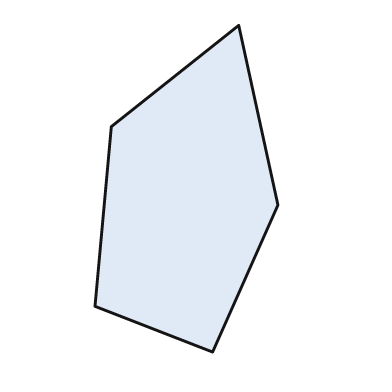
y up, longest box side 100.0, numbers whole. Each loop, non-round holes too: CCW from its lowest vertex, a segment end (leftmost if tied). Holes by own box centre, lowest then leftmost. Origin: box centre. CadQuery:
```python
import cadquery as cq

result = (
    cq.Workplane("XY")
    .moveTo(8.0, -50.0)
    .lineTo(28.0, -5.0)
    .lineTo(16.0, 50.0)
    .lineTo(-23.0, 19.0)
    .lineTo(-28.0, -36.0)
    .close()
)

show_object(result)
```